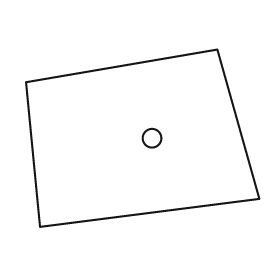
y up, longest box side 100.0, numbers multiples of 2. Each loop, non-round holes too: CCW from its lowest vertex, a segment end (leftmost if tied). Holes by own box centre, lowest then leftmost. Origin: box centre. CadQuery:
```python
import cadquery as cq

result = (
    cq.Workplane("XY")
    .moveTo(-44.0, -38.0)
    .lineTo(50.0, -26.0)
    .lineTo(32.0, 38.0)
    .lineTo(-50.0, 24.0)
    .close()
    .moveTo(4.0, 0.0)
    .circle(4.0)
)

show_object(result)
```